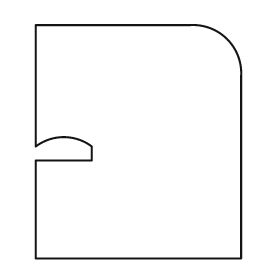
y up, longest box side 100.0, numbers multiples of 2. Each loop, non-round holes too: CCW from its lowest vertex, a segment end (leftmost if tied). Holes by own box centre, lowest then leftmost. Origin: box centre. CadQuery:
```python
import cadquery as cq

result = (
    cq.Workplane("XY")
    .moveTo(-44.0, -50.0)
    .lineTo(44.0, -50.0)
    .lineTo(44.0, 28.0)
    .threePointArc((38.0, 44.0), (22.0, 50.0))
    .lineTo(-44.0, 50.0)
    .lineTo(-44.0, -2.0)
    .threePointArc((-32.0, 2.0), (-20.0, -2.0))
    .lineTo(-20.0, -8.0)
    .lineTo(-44.0, -8.0)
    .close()
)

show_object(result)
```